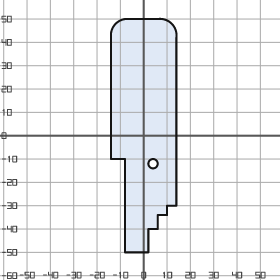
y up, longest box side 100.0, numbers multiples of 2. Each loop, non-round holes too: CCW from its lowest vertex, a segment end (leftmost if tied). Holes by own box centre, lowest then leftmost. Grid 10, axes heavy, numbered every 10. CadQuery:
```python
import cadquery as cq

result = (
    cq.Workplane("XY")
    .moveTo(-8.0, -50.0)
    .lineTo(2.0, -50.0)
    .lineTo(2.0, -40.0)
    .lineTo(6.0, -40.0)
    .lineTo(6.0, -34.0)
    .lineTo(10.0, -34.0)
    .lineTo(10.0, -30.0)
    .lineTo(14.0, -30.0)
    .lineTo(14.0, 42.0)
    .threePointArc((12.0, 48.0), (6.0, 50.0))
    .lineTo(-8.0, 50.0)
    .threePointArc((-12.0, 48.0), (-14.0, 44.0))
    .lineTo(-14.0, -10.0)
    .lineTo(-8.0, -10.0)
    .close()
    .moveTo(4.0, -12.0)
    .circle(2.0)
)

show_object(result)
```